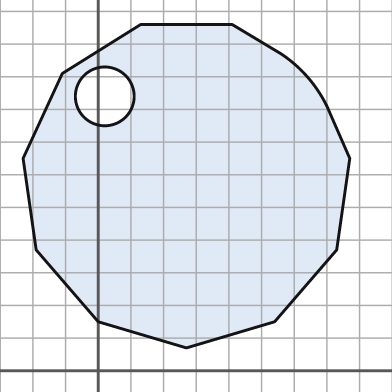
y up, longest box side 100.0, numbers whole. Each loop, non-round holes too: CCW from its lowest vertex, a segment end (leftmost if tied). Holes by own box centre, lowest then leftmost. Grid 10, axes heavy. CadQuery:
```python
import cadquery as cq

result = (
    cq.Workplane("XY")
    .moveTo(27.0, 7.0)
    .lineTo(54.0, 15.0)
    .lineTo(73.0, 37.0)
    .lineTo(77.0, 65.0)
    .lineTo(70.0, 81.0)
    .threePointArc((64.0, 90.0), (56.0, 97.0))
    .lineTo(41.0, 106.0)
    .lineTo(13.0, 106.0)
    .lineTo(-11.0, 91.0)
    .lineTo(-23.0, 65.0)
    .lineTo(-19.0, 37.0)
    .lineTo(0.0, 15.0)
    .close()
    .moveTo(2.0, 84.0)
    .circle(9.0)
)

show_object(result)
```